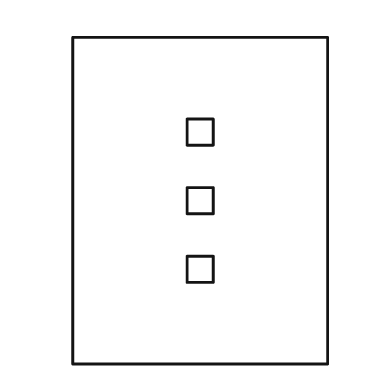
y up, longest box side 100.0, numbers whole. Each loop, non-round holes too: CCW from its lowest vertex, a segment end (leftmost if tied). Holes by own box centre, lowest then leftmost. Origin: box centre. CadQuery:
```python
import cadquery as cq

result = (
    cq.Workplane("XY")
    .moveTo(-39.0, -50.0)
    .lineTo(39.0, -50.0)
    .lineTo(39.0, 50.0)
    .lineTo(-39.0, 50.0)
    .close()
    .moveTo(-4.0, -25.0)
    .lineTo(4.0, -25.0)
    .lineTo(4.0, -17.0)
    .lineTo(-4.0, -17.0)
    .close()
    .moveTo(-4.0, -4.0)
    .lineTo(4.0, -4.0)
    .lineTo(4.0, 4.0)
    .lineTo(-4.0, 4.0)
    .close()
    .moveTo(-4.0, 17.0)
    .lineTo(4.0, 17.0)
    .lineTo(4.0, 25.0)
    .lineTo(-4.0, 25.0)
    .close()
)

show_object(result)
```